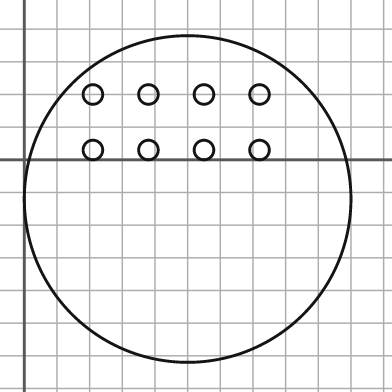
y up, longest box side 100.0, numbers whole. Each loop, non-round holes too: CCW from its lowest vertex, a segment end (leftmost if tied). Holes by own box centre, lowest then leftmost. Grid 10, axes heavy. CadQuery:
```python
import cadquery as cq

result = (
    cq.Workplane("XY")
    .moveTo(50.0, -12.0)
    .circle(50.0)
    .moveTo(21.0, 3.0)
    .circle(3.0)
    .moveTo(38.0, 3.0)
    .circle(3.0)
    .moveTo(55.0, 3.0)
    .circle(3.0)
    .moveTo(72.0, 3.0)
    .circle(3.0)
    .moveTo(21.0, 20.0)
    .circle(3.0)
    .moveTo(38.0, 20.0)
    .circle(3.0)
    .moveTo(55.0, 20.0)
    .circle(3.0)
    .moveTo(72.0, 20.0)
    .circle(3.0)
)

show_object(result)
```